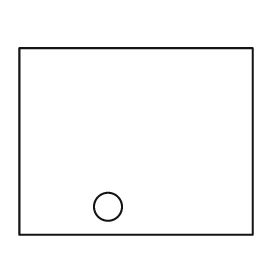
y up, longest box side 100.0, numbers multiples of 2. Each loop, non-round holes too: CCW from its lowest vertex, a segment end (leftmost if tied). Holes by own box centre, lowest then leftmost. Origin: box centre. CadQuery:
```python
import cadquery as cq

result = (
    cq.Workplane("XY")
    .moveTo(-50.0, -40.0)
    .lineTo(50.0, -40.0)
    .lineTo(50.0, 40.0)
    .lineTo(-50.0, 40.0)
    .close()
    .moveTo(-12.0, -28.0)
    .circle(6.0)
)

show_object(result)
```